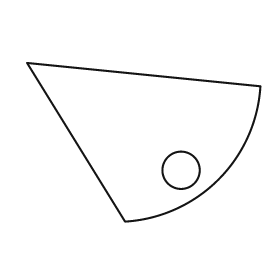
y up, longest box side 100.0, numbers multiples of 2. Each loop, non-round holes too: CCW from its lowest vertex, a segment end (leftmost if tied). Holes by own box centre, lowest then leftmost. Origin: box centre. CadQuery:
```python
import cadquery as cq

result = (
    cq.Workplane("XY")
    .moveTo(-8.0, -34.0)
    .threePointArc((32.0, -16.0), (50.0, 24.0))
    .lineTo(-50.0, 34.0)
    .close()
    .moveTo(16.0, -12.0)
    .circle(8.0)
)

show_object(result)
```